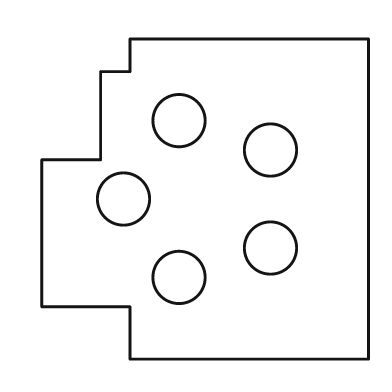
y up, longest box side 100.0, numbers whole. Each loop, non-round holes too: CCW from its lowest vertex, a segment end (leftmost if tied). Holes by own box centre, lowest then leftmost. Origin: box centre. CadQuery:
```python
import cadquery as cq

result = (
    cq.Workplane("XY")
    .moveTo(-23.0, -49.0)
    .lineTo(50.0, -49.0)
    .lineTo(50.0, 49.0)
    .lineTo(-23.0, 49.0)
    .lineTo(-23.0, 39.0)
    .lineTo(-32.0, 39.0)
    .lineTo(-32.0, 12.0)
    .lineTo(-50.0, 12.0)
    .lineTo(-50.0, -33.0)
    .lineTo(-23.0, -33.0)
    .close()
    .moveTo(-8.0, -24.0)
    .circle(8.0)
    .moveTo(20.0, -15.0)
    .circle(8.0)
    .moveTo(-25.0, 0.0)
    .circle(8.0)
    .moveTo(20.0, 15.0)
    .circle(8.0)
    .moveTo(-8.0, 24.0)
    .circle(8.0)
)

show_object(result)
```